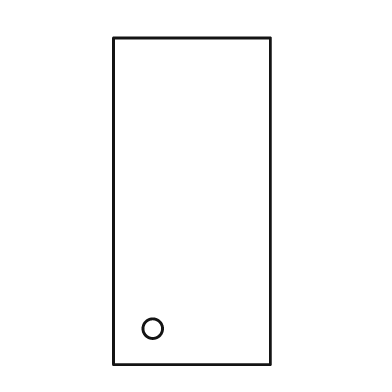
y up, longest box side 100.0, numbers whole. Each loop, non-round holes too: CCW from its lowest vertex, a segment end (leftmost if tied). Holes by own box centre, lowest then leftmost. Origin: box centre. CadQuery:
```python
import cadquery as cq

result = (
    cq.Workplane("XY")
    .moveTo(-24.0, -50.0)
    .lineTo(24.0, -50.0)
    .lineTo(24.0, 50.0)
    .lineTo(-24.0, 50.0)
    .close()
    .moveTo(-12.0, -39.0)
    .circle(3.0)
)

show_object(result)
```